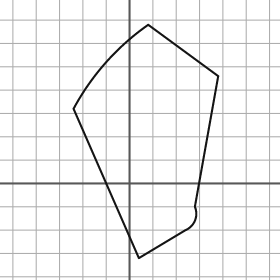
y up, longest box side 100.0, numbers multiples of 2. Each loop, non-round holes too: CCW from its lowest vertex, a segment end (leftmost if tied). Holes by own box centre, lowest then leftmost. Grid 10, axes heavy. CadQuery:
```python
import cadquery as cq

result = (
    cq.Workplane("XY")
    .moveTo(4.0, -32.0)
    .lineTo(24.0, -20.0)
    .threePointArc((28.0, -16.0), (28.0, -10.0))
    .lineTo(38.0, 46.0)
    .lineTo(8.0, 68.0)
    .threePointArc((-10.0, 52.0), (-24.0, 32.0))
    .close()
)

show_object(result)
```